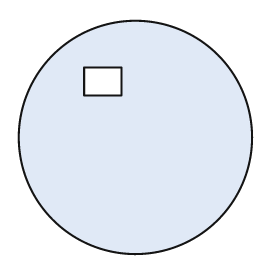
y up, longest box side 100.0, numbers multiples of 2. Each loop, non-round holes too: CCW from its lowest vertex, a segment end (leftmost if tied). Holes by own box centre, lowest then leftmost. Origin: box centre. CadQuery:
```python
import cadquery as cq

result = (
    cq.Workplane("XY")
    .moveTo(0.0, 0.0)
    .circle(50.0)
    .moveTo(-22.0, 18.0)
    .lineTo(-6.0, 18.0)
    .lineTo(-6.0, 30.0)
    .lineTo(-22.0, 30.0)
    .close()
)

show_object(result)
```